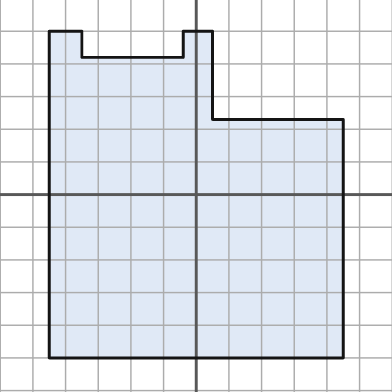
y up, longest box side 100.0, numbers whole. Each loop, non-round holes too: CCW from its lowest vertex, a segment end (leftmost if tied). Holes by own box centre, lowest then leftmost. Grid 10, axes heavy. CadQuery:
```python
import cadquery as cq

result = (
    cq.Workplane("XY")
    .moveTo(-45.0, -50.0)
    .lineTo(45.0, -50.0)
    .lineTo(45.0, 23.0)
    .lineTo(5.0, 23.0)
    .lineTo(5.0, 50.0)
    .lineTo(-4.0, 50.0)
    .lineTo(-4.0, 42.0)
    .lineTo(-35.0, 42.0)
    .lineTo(-35.0, 50.0)
    .lineTo(-45.0, 50.0)
    .close()
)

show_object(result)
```